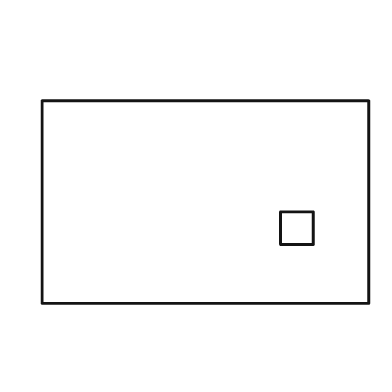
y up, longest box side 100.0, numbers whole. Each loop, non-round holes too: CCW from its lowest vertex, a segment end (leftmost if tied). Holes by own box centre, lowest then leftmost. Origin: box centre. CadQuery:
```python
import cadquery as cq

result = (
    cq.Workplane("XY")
    .moveTo(-50.0, -31.0)
    .lineTo(50.0, -31.0)
    .lineTo(50.0, 31.0)
    .lineTo(-50.0, 31.0)
    .close()
    .moveTo(23.0, -13.0)
    .lineTo(33.0, -13.0)
    .lineTo(33.0, -3.0)
    .lineTo(23.0, -3.0)
    .close()
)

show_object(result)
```